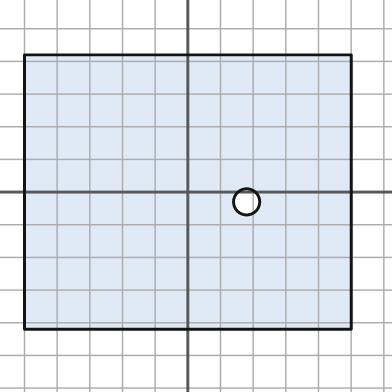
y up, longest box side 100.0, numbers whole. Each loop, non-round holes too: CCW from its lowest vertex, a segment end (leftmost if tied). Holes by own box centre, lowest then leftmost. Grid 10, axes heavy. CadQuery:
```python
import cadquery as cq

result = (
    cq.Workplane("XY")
    .moveTo(-50.0, -42.0)
    .lineTo(50.0, -42.0)
    .lineTo(50.0, 42.0)
    .lineTo(-50.0, 42.0)
    .close()
    .moveTo(18.0, -3.0)
    .circle(4.0)
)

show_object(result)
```